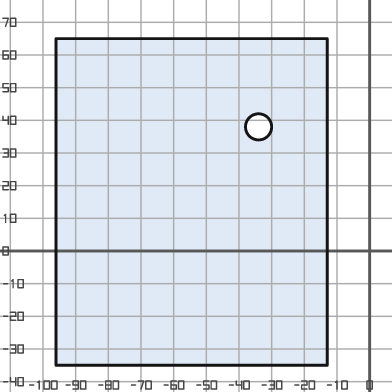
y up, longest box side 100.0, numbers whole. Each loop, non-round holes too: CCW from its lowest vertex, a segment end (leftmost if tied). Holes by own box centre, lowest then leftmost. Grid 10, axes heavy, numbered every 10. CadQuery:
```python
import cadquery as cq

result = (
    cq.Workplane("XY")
    .moveTo(-96.0, -35.0)
    .lineTo(-13.0, -35.0)
    .lineTo(-13.0, 65.0)
    .lineTo(-96.0, 65.0)
    .close()
    .moveTo(-34.0, 38.0)
    .circle(4.0)
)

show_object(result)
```